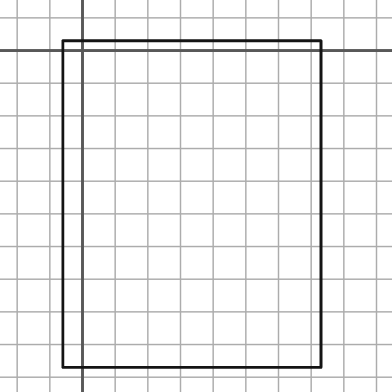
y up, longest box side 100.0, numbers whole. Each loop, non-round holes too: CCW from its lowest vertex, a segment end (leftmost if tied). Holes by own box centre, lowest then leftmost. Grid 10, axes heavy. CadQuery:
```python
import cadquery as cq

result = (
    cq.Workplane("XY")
    .moveTo(-6.0, -97.0)
    .lineTo(73.0, -97.0)
    .lineTo(73.0, 3.0)
    .lineTo(-6.0, 3.0)
    .close()
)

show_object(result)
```